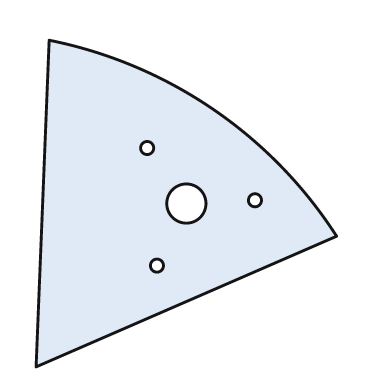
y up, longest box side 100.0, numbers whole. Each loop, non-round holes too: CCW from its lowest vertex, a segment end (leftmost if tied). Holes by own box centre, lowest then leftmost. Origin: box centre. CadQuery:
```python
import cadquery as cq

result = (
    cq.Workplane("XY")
    .moveTo(-46.0, -50.0)
    .lineTo(46.0, -10.0)
    .threePointArc((8.0, 29.0), (-42.0, 50.0))
    .close()
    .moveTo(-9.0, -19.0)
    .circle(2.0)
    .moveTo(0.0, 0.0)
    .circle(6.0)
    .moveTo(21.0, 1.0)
    .circle(2.0)
    .moveTo(-12.0, 17.0)
    .circle(2.0)
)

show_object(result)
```